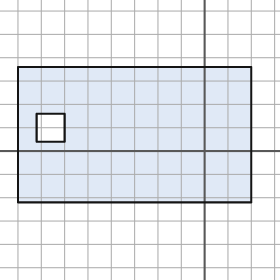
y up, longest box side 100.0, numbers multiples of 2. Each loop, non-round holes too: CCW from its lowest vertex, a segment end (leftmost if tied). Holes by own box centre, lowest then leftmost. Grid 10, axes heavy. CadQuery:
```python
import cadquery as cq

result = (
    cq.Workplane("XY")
    .moveTo(-80.0, -22.0)
    .lineTo(20.0, -22.0)
    .lineTo(20.0, 36.0)
    .lineTo(-80.0, 36.0)
    .close()
    .moveTo(-72.0, 4.0)
    .lineTo(-60.0, 4.0)
    .lineTo(-60.0, 16.0)
    .lineTo(-72.0, 16.0)
    .close()
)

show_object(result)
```